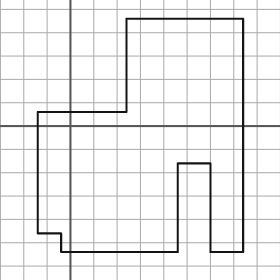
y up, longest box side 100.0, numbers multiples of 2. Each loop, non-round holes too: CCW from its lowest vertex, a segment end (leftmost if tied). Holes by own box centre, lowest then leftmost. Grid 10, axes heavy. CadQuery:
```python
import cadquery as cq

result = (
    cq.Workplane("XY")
    .moveTo(-4.0, -54.0)
    .lineTo(46.0, -54.0)
    .lineTo(46.0, -16.0)
    .lineTo(60.0, -16.0)
    .lineTo(60.0, -54.0)
    .lineTo(74.0, -54.0)
    .lineTo(74.0, 46.0)
    .lineTo(24.0, 46.0)
    .lineTo(24.0, 6.0)
    .lineTo(-14.0, 6.0)
    .lineTo(-14.0, -46.0)
    .lineTo(-4.0, -46.0)
    .close()
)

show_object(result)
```